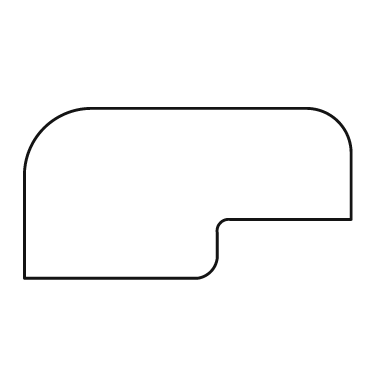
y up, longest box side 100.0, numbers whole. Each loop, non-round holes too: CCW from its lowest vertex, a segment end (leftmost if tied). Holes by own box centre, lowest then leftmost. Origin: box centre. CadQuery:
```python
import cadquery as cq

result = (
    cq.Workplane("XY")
    .moveTo(-50.0, -26.0)
    .lineTo(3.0, -26.0)
    .threePointArc((7.0, -24.0), (9.0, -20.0))
    .lineTo(9.0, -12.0)
    .threePointArc((10.0, -9.0), (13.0, -8.0))
    .lineTo(50.0, -8.0)
    .lineTo(50.0, 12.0)
    .threePointArc((46.0, 22.0), (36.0, 26.0))
    .lineTo(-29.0, 26.0)
    .threePointArc((-44.0, 20.0), (-50.0, 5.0))
    .close()
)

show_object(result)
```